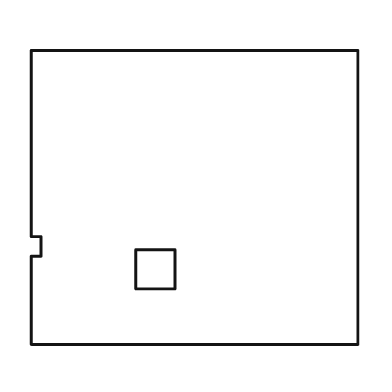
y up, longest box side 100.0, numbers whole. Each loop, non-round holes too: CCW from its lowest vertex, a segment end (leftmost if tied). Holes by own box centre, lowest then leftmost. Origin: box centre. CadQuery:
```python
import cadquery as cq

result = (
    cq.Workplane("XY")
    .moveTo(-50.0, -45.0)
    .lineTo(50.0, -45.0)
    .lineTo(50.0, 45.0)
    .lineTo(-50.0, 45.0)
    .lineTo(-50.0, -12.0)
    .lineTo(-47.0, -12.0)
    .lineTo(-47.0, -18.0)
    .lineTo(-50.0, -18.0)
    .close()
    .moveTo(-18.0, -28.0)
    .lineTo(-6.0, -28.0)
    .lineTo(-6.0, -16.0)
    .lineTo(-18.0, -16.0)
    .close()
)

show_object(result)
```